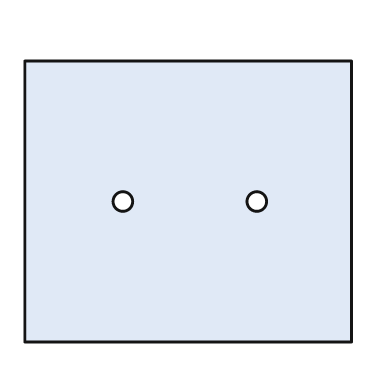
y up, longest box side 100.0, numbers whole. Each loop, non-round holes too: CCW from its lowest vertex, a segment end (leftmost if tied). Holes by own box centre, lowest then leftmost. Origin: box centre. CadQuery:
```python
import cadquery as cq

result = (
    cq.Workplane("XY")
    .moveTo(-50.0, -43.0)
    .lineTo(50.0, -43.0)
    .lineTo(50.0, 43.0)
    .lineTo(-50.0, 43.0)
    .close()
    .moveTo(-20.0, 0.0)
    .circle(3.0)
    .moveTo(21.0, 0.0)
    .circle(3.0)
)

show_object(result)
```